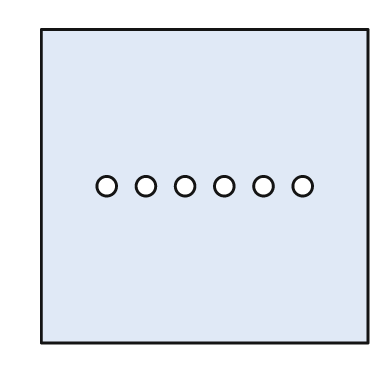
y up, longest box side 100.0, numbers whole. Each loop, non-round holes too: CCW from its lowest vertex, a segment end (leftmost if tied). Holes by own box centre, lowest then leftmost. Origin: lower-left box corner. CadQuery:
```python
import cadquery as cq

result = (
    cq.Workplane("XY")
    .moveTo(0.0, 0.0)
    .lineTo(100.0, 0.0)
    .lineTo(100.0, 96.0)
    .lineTo(0.0, 96.0)
    .close()
    .moveTo(20.0, 48.0)
    .circle(3.0)
    .moveTo(32.0, 48.0)
    .circle(3.0)
    .moveTo(44.0, 48.0)
    .circle(3.0)
    .moveTo(56.0, 48.0)
    .circle(3.0)
    .moveTo(68.0, 48.0)
    .circle(3.0)
    .moveTo(80.0, 48.0)
    .circle(3.0)
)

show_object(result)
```